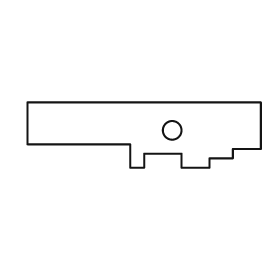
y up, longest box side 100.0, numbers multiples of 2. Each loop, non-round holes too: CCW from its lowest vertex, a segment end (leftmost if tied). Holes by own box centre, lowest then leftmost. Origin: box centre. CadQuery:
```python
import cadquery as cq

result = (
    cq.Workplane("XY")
    .moveTo(-6.0, -14.0)
    .lineTo(0.0, -14.0)
    .lineTo(0.0, -8.0)
    .lineTo(16.0, -8.0)
    .lineTo(16.0, -14.0)
    .lineTo(28.0, -14.0)
    .lineTo(28.0, -10.0)
    .lineTo(38.0, -10.0)
    .lineTo(38.0, -6.0)
    .lineTo(50.0, -6.0)
    .lineTo(50.0, 14.0)
    .lineTo(-50.0, 14.0)
    .lineTo(-50.0, -4.0)
    .lineTo(-6.0, -4.0)
    .close()
    .moveTo(12.0, 2.0)
    .circle(4.0)
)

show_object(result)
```